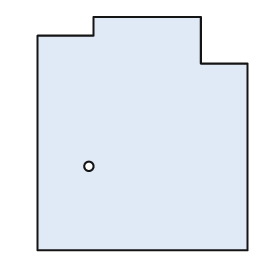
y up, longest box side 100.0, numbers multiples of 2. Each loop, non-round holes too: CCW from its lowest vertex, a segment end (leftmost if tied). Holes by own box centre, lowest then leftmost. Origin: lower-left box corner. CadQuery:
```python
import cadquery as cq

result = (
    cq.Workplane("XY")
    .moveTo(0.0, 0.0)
    .lineTo(90.0, 0.0)
    .lineTo(90.0, 80.0)
    .lineTo(70.0, 80.0)
    .lineTo(70.0, 100.0)
    .lineTo(24.0, 100.0)
    .lineTo(24.0, 92.0)
    .lineTo(0.0, 92.0)
    .close()
    .moveTo(22.0, 36.0)
    .circle(2.0)
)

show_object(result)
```